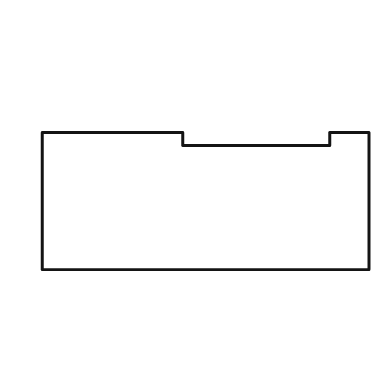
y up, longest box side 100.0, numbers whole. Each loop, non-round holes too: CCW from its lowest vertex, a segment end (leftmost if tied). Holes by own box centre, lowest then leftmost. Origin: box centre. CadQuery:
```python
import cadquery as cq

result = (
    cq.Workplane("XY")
    .moveTo(-50.0, -21.0)
    .lineTo(50.0, -21.0)
    .lineTo(50.0, 21.0)
    .lineTo(38.0, 21.0)
    .lineTo(38.0, 17.0)
    .lineTo(-7.0, 17.0)
    .lineTo(-7.0, 21.0)
    .lineTo(-50.0, 21.0)
    .close()
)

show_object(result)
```